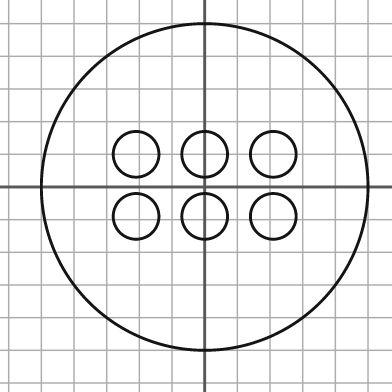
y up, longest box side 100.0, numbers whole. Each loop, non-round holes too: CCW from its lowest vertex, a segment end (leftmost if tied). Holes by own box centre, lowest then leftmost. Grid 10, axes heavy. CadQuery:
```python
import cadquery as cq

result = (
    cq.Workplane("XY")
    .moveTo(0.0, 0.0)
    .circle(50.0)
    .moveTo(-21.0, -9.0)
    .circle(7.0)
    .moveTo(0.0, -9.0)
    .circle(7.0)
    .moveTo(21.0, -9.0)
    .circle(7.0)
    .moveTo(-21.0, 10.0)
    .circle(7.0)
    .moveTo(0.0, 10.0)
    .circle(7.0)
    .moveTo(21.0, 10.0)
    .circle(7.0)
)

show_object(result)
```